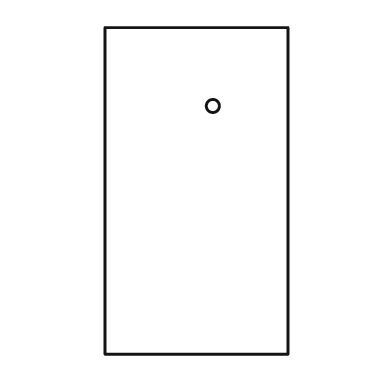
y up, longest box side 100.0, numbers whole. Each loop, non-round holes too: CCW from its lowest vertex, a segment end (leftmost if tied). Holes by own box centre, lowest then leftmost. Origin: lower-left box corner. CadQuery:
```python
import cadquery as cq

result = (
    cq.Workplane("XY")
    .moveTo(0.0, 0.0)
    .lineTo(56.0, 0.0)
    .lineTo(56.0, 100.0)
    .lineTo(0.0, 100.0)
    .close()
    .moveTo(33.0, 76.0)
    .circle(2.0)
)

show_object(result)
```